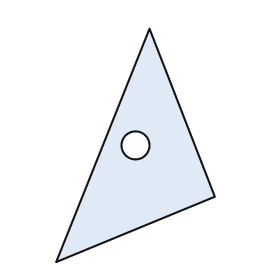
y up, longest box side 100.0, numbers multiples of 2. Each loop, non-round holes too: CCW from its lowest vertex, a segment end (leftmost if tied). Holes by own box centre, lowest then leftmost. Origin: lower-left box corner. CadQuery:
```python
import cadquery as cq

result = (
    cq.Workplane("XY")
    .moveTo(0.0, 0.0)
    .lineTo(68.0, 28.0)
    .lineTo(40.0, 100.0)
    .close()
    .moveTo(34.0, 50.0)
    .circle(6.0)
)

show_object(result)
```